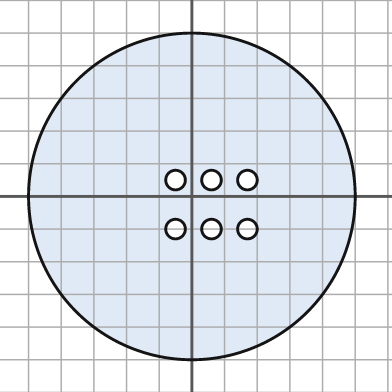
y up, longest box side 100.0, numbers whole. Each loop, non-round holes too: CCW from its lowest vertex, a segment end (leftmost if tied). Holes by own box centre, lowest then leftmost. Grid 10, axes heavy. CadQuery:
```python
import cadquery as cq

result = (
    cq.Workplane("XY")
    .moveTo(0.0, 0.0)
    .circle(50.0)
    .moveTo(-5.0, -10.0)
    .circle(3.0)
    .moveTo(6.0, -10.0)
    .circle(3.0)
    .moveTo(17.0, -10.0)
    .circle(3.0)
    .moveTo(-5.0, 5.0)
    .circle(3.0)
    .moveTo(6.0, 5.0)
    .circle(3.0)
    .moveTo(17.0, 5.0)
    .circle(3.0)
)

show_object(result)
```